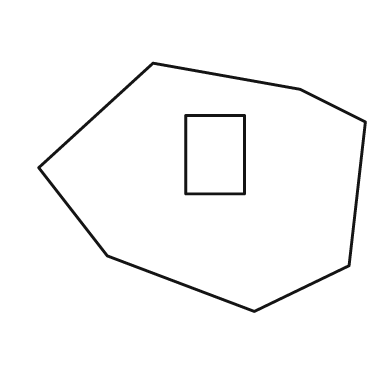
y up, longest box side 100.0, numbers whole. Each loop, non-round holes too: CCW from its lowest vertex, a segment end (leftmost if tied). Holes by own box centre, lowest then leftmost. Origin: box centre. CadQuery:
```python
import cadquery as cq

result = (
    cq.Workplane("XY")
    .moveTo(16.0, -38.0)
    .lineTo(45.0, -24.0)
    .lineTo(50.0, 20.0)
    .lineTo(30.0, 30.0)
    .lineTo(-15.0, 38.0)
    .lineTo(-50.0, 6.0)
    .lineTo(-29.0, -21.0)
    .close()
    .moveTo(-5.0, -2.0)
    .lineTo(13.0, -2.0)
    .lineTo(13.0, 22.0)
    .lineTo(-5.0, 22.0)
    .close()
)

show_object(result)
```